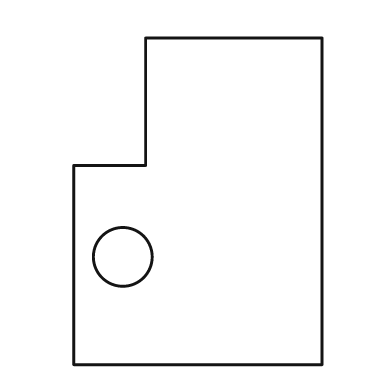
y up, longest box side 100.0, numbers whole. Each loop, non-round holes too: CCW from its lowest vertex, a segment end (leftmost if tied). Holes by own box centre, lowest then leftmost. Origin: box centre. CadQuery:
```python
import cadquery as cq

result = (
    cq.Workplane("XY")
    .moveTo(-38.0, -50.0)
    .lineTo(38.0, -50.0)
    .lineTo(38.0, 50.0)
    .lineTo(-16.0, 50.0)
    .lineTo(-16.0, 11.0)
    .lineTo(-38.0, 11.0)
    .close()
    .moveTo(-23.0, -17.0)
    .circle(9.0)
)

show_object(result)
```